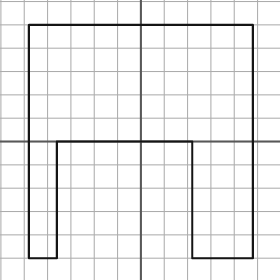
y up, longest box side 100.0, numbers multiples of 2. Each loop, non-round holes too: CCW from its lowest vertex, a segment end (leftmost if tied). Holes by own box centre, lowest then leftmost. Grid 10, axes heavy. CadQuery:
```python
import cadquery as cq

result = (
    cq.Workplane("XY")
    .moveTo(-48.0, -50.0)
    .lineTo(-36.0, -50.0)
    .lineTo(-36.0, 0.0)
    .lineTo(22.0, 0.0)
    .lineTo(22.0, -50.0)
    .lineTo(48.0, -50.0)
    .lineTo(48.0, 50.0)
    .lineTo(-48.0, 50.0)
    .close()
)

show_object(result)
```